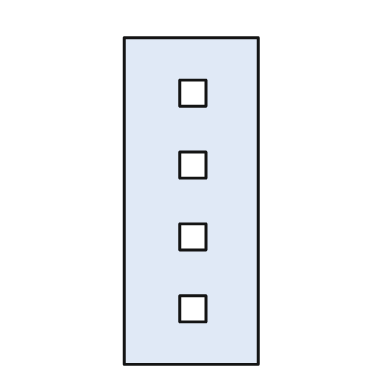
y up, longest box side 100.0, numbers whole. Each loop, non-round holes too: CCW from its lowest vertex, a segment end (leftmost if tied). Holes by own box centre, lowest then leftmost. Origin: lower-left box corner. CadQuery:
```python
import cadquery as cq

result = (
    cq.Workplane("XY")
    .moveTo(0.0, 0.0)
    .lineTo(41.0, 0.0)
    .lineTo(41.0, 100.0)
    .lineTo(0.0, 100.0)
    .close()
    .moveTo(17.0, 13.0)
    .lineTo(25.0, 13.0)
    .lineTo(25.0, 21.0)
    .lineTo(17.0, 21.0)
    .close()
    .moveTo(17.0, 35.0)
    .lineTo(25.0, 35.0)
    .lineTo(25.0, 43.0)
    .lineTo(17.0, 43.0)
    .close()
    .moveTo(17.0, 57.0)
    .lineTo(25.0, 57.0)
    .lineTo(25.0, 65.0)
    .lineTo(17.0, 65.0)
    .close()
    .moveTo(17.0, 79.0)
    .lineTo(25.0, 79.0)
    .lineTo(25.0, 87.0)
    .lineTo(17.0, 87.0)
    .close()
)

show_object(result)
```